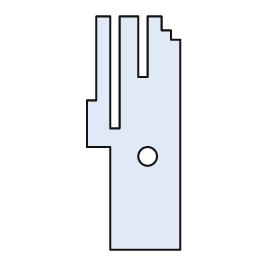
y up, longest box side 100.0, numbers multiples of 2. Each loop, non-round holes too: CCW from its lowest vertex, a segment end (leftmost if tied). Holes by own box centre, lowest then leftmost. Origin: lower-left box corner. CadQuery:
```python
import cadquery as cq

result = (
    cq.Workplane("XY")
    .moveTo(10.0, 0.0)
    .lineTo(40.0, 0.0)
    .lineTo(40.0, 90.0)
    .lineTo(36.0, 90.0)
    .lineTo(36.0, 94.0)
    .lineTo(32.0, 94.0)
    .lineTo(32.0, 100.0)
    .lineTo(26.0, 100.0)
    .lineTo(26.0, 74.0)
    .lineTo(22.0, 74.0)
    .lineTo(22.0, 100.0)
    .lineTo(14.0, 100.0)
    .lineTo(14.0, 52.0)
    .lineTo(10.0, 52.0)
    .lineTo(10.0, 100.0)
    .lineTo(4.0, 100.0)
    .lineTo(4.0, 64.0)
    .lineTo(0.0, 64.0)
    .lineTo(0.0, 44.0)
    .lineTo(10.0, 44.0)
    .close()
    .moveTo(26.0, 40.0)
    .circle(4.0)
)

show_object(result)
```